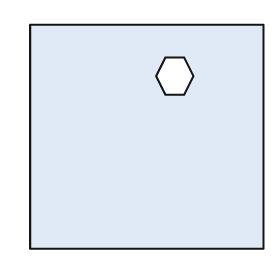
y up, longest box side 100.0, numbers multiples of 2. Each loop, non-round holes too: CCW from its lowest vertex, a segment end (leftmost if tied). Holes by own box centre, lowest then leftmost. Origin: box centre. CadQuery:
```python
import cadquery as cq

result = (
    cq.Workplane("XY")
    .moveTo(-50.0, -48.0)
    .lineTo(50.0, -48.0)
    .lineTo(50.0, 48.0)
    .lineTo(-50.0, 48.0)
    .close()
    .moveTo(8.0, 18.0)
    .lineTo(16.0, 18.0)
    .lineTo(20.0, 26.0)
    .lineTo(16.0, 34.0)
    .lineTo(8.0, 34.0)
    .lineTo(4.0, 26.0)
    .close()
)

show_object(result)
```